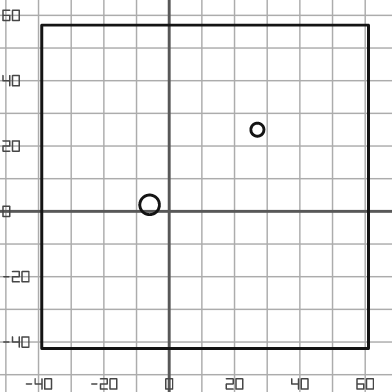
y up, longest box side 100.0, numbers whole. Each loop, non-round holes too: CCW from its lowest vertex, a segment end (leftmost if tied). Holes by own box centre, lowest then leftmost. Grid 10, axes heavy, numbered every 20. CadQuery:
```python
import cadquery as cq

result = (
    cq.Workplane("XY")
    .moveTo(-39.0, -42.0)
    .lineTo(61.0, -42.0)
    .lineTo(61.0, 57.0)
    .lineTo(-39.0, 57.0)
    .close()
    .moveTo(-6.0, 2.0)
    .circle(3.0)
    .moveTo(27.0, 25.0)
    .circle(2.0)
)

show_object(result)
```